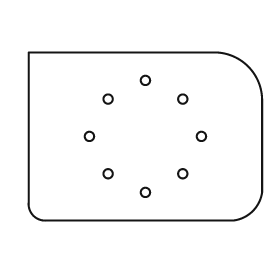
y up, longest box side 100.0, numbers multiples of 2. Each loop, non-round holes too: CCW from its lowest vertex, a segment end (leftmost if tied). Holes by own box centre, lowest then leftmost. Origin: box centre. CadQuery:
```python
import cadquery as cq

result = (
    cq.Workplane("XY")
    .moveTo(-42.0, -36.0)
    .lineTo(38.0, -36.0)
    .threePointArc((46.0, -32.0), (50.0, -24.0))
    .lineTo(50.0, 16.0)
    .threePointArc((44.0, 30.0), (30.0, 36.0))
    .lineTo(-50.0, 36.0)
    .lineTo(-50.0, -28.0)
    .threePointArc((-48.0, -34.0), (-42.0, -36.0))
    .close()
    .moveTo(0.0, -24.0)
    .circle(2.0)
    .moveTo(-16.0, -16.0)
    .circle(2.0)
    .moveTo(16.0, -16.0)
    .circle(2.0)
    .moveTo(-24.0, 0.0)
    .circle(2.0)
    .moveTo(24.0, 0.0)
    .circle(2.0)
    .moveTo(-16.0, 16.0)
    .circle(2.0)
    .moveTo(16.0, 16.0)
    .circle(2.0)
    .moveTo(0.0, 24.0)
    .circle(2.0)
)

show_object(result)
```